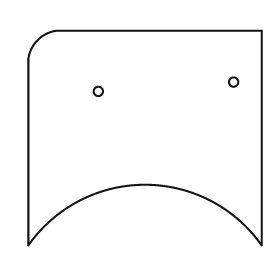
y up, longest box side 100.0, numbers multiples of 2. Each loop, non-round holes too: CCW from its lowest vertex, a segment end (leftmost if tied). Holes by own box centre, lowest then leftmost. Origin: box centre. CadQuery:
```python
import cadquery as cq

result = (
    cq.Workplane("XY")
    .moveTo(-50.0, -46.0)
    .threePointArc((0.0, -20.0), (50.0, -46.0))
    .lineTo(50.0, 46.0)
    .lineTo(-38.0, 46.0)
    .threePointArc((-46.0, 42.0), (-50.0, 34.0))
    .close()
    .moveTo(-20.0, 20.0)
    .circle(2.0)
    .moveTo(38.0, 24.0)
    .circle(2.0)
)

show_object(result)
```